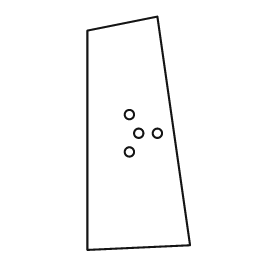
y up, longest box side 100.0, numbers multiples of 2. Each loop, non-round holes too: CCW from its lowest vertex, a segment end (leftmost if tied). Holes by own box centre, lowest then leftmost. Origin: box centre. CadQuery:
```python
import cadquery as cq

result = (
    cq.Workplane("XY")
    .moveTo(-22.0, -50.0)
    .lineTo(22.0, -48.0)
    .lineTo(8.0, 50.0)
    .lineTo(-22.0, 44.0)
    .close()
    .moveTo(-4.0, -8.0)
    .circle(2.0)
    .moveTo(0.0, 0.0)
    .circle(2.0)
    .moveTo(8.0, 0.0)
    .circle(2.0)
    .moveTo(-4.0, 8.0)
    .circle(2.0)
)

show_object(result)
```